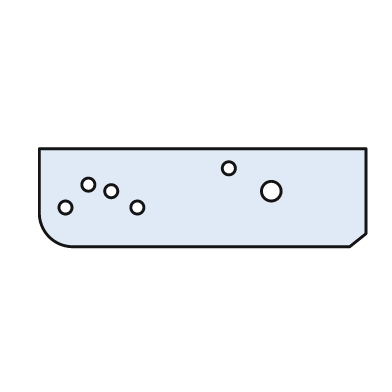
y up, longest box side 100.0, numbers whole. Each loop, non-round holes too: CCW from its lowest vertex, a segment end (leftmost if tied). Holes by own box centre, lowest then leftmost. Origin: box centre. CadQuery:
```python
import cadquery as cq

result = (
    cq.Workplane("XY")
    .moveTo(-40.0, -15.0)
    .lineTo(45.0, -15.0)
    .lineTo(50.0, -11.0)
    .lineTo(50.0, 15.0)
    .lineTo(-50.0, 15.0)
    .lineTo(-50.0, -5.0)
    .threePointArc((-47.0, -12.0), (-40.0, -15.0))
    .close()
    .moveTo(-42.0, -3.0)
    .circle(2.0)
    .moveTo(-20.0, -3.0)
    .circle(2.0)
    .moveTo(-28.0, 2.0)
    .circle(2.0)
    .moveTo(21.0, 2.0)
    .circle(3.0)
    .moveTo(-35.0, 4.0)
    .circle(2.0)
    .moveTo(8.0, 9.0)
    .circle(2.0)
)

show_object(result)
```